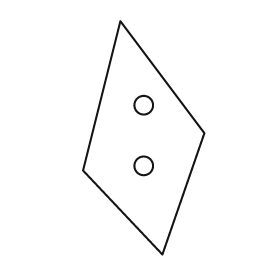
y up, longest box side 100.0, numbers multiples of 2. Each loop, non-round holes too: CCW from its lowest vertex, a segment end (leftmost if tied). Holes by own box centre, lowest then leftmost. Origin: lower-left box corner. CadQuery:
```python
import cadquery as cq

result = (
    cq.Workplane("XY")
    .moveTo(34.0, 0.0)
    .lineTo(52.0, 52.0)
    .lineTo(16.0, 100.0)
    .lineTo(0.0, 36.0)
    .close()
    .moveTo(26.0, 38.0)
    .circle(4.0)
    .moveTo(26.0, 64.0)
    .circle(4.0)
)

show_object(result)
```